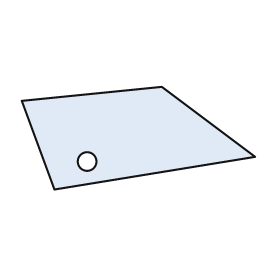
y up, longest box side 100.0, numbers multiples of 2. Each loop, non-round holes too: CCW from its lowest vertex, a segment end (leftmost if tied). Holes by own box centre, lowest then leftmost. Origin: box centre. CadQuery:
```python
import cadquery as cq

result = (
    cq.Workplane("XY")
    .moveTo(-36.0, -22.0)
    .lineTo(50.0, -8.0)
    .lineTo(10.0, 22.0)
    .lineTo(-50.0, 16.0)
    .close()
    .moveTo(-22.0, -10.0)
    .circle(4.0)
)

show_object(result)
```